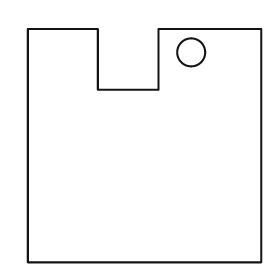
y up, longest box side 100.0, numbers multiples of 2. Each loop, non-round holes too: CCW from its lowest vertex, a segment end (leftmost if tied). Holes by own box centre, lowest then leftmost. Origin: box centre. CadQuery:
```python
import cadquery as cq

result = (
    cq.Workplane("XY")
    .moveTo(-50.0, -50.0)
    .lineTo(50.0, -50.0)
    .lineTo(50.0, 50.0)
    .lineTo(6.0, 50.0)
    .lineTo(6.0, 24.0)
    .lineTo(-20.0, 24.0)
    .lineTo(-20.0, 50.0)
    .lineTo(-50.0, 50.0)
    .close()
    .moveTo(20.0, 40.0)
    .circle(6.0)
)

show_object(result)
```